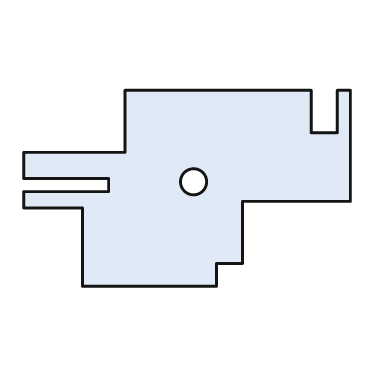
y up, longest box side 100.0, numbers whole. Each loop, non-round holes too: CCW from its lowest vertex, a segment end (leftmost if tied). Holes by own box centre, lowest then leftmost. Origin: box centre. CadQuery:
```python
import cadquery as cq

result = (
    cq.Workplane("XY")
    .moveTo(-32.0, -30.0)
    .lineTo(9.0, -30.0)
    .lineTo(9.0, -23.0)
    .lineTo(17.0, -23.0)
    .lineTo(17.0, -4.0)
    .lineTo(50.0, -4.0)
    .lineTo(50.0, 30.0)
    .lineTo(46.0, 30.0)
    .lineTo(46.0, 17.0)
    .lineTo(38.0, 17.0)
    .lineTo(38.0, 30.0)
    .lineTo(-19.0, 30.0)
    .lineTo(-19.0, 11.0)
    .lineTo(-50.0, 11.0)
    .lineTo(-50.0, 3.0)
    .lineTo(-24.0, 3.0)
    .lineTo(-24.0, -1.0)
    .lineTo(-50.0, -1.0)
    .lineTo(-50.0, -6.0)
    .lineTo(-32.0, -6.0)
    .close()
    .moveTo(2.0, 2.0)
    .circle(4.0)
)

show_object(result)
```